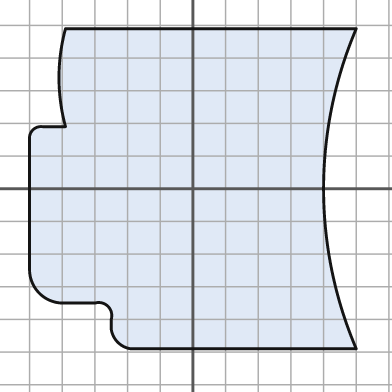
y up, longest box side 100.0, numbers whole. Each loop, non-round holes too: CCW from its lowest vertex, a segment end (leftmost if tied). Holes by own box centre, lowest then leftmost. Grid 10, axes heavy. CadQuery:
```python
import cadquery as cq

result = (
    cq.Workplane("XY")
    .moveTo(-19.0, -49.0)
    .lineTo(50.0, -49.0)
    .threePointArc((40.0, 0.0), (50.0, 49.0))
    .lineTo(-39.0, 49.0)
    .threePointArc((-41.0, 34.0), (-39.0, 19.0))
    .lineTo(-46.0, 19.0)
    .threePointArc((-49.0, 18.0), (-50.0, 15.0))
    .lineTo(-50.0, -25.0)
    .threePointArc((-47.0, -32.0), (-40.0, -35.0))
    .lineTo(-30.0, -35.0)
    .threePointArc((-26.0, -36.0), (-25.0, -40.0))
    .lineTo(-25.0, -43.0)
    .threePointArc((-23.0, -47.0), (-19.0, -49.0))
    .close()
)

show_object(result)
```